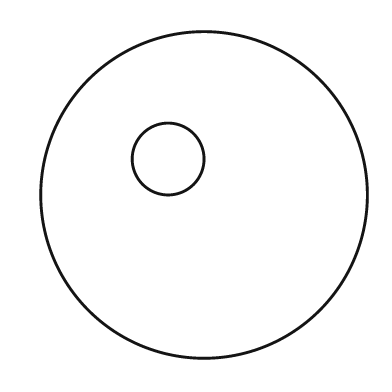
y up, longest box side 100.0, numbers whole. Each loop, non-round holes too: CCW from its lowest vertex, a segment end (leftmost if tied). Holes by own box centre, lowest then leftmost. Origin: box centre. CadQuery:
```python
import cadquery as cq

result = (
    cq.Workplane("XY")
    .moveTo(0.0, 0.0)
    .circle(50.0)
    .moveTo(-11.0, 11.0)
    .circle(11.0)
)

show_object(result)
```